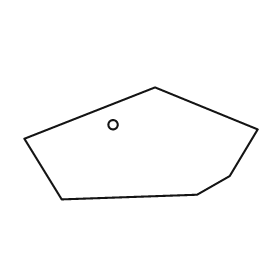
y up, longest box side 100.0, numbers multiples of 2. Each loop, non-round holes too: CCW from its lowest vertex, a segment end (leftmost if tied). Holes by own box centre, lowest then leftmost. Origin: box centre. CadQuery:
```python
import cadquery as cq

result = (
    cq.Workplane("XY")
    .moveTo(-34.0, -24.0)
    .lineTo(24.0, -22.0)
    .lineTo(38.0, -14.0)
    .lineTo(50.0, 6.0)
    .lineTo(6.0, 24.0)
    .lineTo(-50.0, 2.0)
    .close()
    .moveTo(-12.0, 8.0)
    .circle(2.0)
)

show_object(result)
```